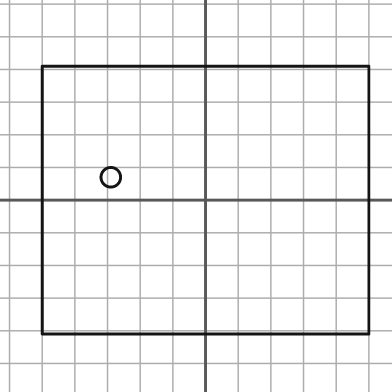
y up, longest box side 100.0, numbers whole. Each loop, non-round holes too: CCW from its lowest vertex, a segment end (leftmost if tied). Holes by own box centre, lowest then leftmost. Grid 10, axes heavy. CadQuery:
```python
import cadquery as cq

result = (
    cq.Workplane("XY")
    .moveTo(-50.0, -41.0)
    .lineTo(50.0, -41.0)
    .lineTo(50.0, 41.0)
    .lineTo(-50.0, 41.0)
    .close()
    .moveTo(-29.0, 7.0)
    .circle(3.0)
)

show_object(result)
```